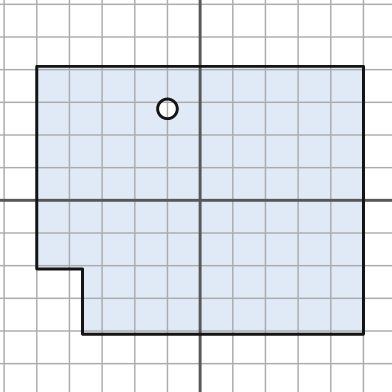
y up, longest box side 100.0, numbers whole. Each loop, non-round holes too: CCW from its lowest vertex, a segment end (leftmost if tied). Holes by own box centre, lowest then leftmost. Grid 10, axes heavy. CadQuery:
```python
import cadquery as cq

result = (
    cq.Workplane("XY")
    .moveTo(-36.0, -41.0)
    .lineTo(50.0, -41.0)
    .lineTo(50.0, 41.0)
    .lineTo(-50.0, 41.0)
    .lineTo(-50.0, -21.0)
    .lineTo(-36.0, -21.0)
    .close()
    .moveTo(-10.0, 28.0)
    .circle(3.0)
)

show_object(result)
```